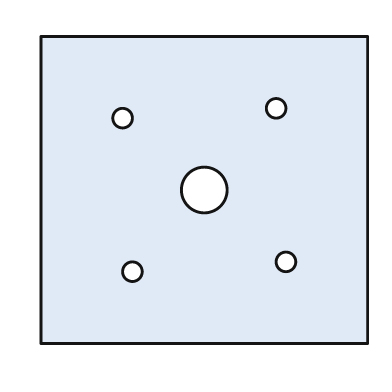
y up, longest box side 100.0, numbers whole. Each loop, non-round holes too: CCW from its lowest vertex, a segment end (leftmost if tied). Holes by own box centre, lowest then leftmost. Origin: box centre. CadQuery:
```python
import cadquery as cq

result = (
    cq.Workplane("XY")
    .moveTo(-50.0, -47.0)
    .lineTo(50.0, -47.0)
    .lineTo(50.0, 47.0)
    .lineTo(-50.0, 47.0)
    .close()
    .moveTo(-22.0, -25.0)
    .circle(3.0)
    .moveTo(25.0, -22.0)
    .circle(3.0)
    .moveTo(0.0, 0.0)
    .circle(7.0)
    .moveTo(-25.0, 22.0)
    .circle(3.0)
    .moveTo(22.0, 25.0)
    .circle(3.0)
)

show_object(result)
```